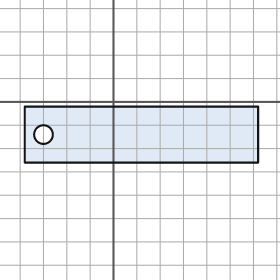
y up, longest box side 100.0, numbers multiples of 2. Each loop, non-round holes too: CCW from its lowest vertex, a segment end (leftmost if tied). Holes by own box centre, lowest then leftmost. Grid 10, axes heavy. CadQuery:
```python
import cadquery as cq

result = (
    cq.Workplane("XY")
    .moveTo(-38.0, -26.0)
    .lineTo(62.0, -26.0)
    .lineTo(62.0, -2.0)
    .lineTo(-38.0, -2.0)
    .close()
    .moveTo(-30.0, -14.0)
    .circle(4.0)
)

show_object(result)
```